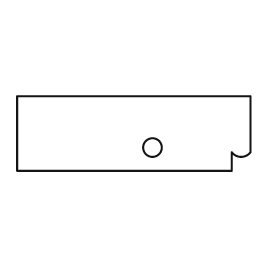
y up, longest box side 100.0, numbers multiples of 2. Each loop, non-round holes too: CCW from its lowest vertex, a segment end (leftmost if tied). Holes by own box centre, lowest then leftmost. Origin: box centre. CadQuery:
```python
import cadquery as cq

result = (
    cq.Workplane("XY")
    .moveTo(-50.0, -16.0)
    .lineTo(42.0, -16.0)
    .lineTo(42.0, -8.0)
    .threePointArc((46.0, -10.0), (50.0, -8.0))
    .lineTo(50.0, 16.0)
    .lineTo(-50.0, 16.0)
    .close()
    .moveTo(8.0, -6.0)
    .circle(4.0)
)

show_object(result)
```